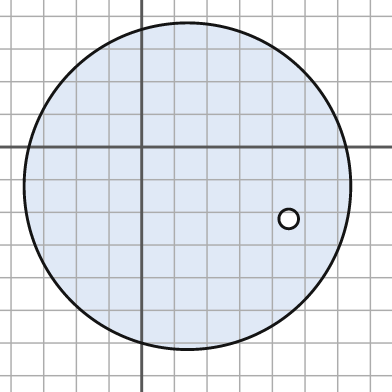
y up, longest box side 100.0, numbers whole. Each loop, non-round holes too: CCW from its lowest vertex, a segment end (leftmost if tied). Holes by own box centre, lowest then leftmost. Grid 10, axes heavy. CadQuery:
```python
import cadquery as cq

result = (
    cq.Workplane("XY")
    .moveTo(14.0, -12.0)
    .circle(50.0)
    .moveTo(45.0, -22.0)
    .circle(3.0)
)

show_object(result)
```